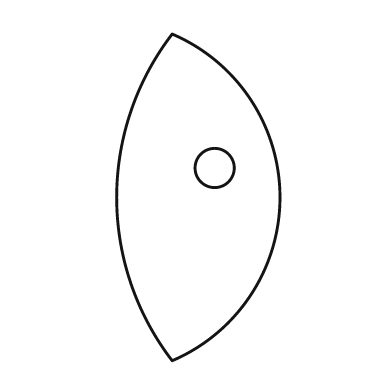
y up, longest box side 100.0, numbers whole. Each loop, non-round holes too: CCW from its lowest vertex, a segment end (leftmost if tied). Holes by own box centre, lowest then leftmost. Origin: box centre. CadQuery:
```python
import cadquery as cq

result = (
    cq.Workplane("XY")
    .moveTo(-8.0, -50.0)
    .threePointArc((25.0, 0.0), (-8.0, 50.0))
    .threePointArc((-25.0, 0.0), (-8.0, -50.0))
    .close()
    .moveTo(5.0, 9.0)
    .circle(6.0)
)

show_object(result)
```